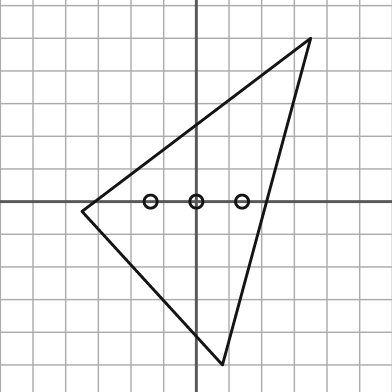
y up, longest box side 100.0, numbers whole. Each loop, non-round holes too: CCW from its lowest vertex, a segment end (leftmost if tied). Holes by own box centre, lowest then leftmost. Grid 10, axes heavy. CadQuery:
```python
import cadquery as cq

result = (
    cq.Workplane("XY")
    .moveTo(8.0, -50.0)
    .lineTo(35.0, 50.0)
    .lineTo(-35.0, -3.0)
    .close()
    .moveTo(-14.0, 0.0)
    .circle(2.0)
    .moveTo(0.0, 0.0)
    .circle(2.0)
    .moveTo(14.0, 0.0)
    .circle(2.0)
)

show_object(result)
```